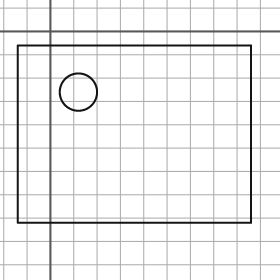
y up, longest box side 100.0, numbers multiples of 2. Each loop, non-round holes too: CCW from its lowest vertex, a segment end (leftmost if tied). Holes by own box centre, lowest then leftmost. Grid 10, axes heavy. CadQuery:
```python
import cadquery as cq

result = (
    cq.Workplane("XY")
    .moveTo(-14.0, -82.0)
    .lineTo(86.0, -82.0)
    .lineTo(86.0, -6.0)
    .lineTo(-14.0, -6.0)
    .close()
    .moveTo(12.0, -26.0)
    .circle(8.0)
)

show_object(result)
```